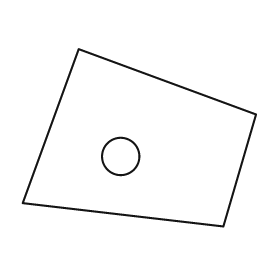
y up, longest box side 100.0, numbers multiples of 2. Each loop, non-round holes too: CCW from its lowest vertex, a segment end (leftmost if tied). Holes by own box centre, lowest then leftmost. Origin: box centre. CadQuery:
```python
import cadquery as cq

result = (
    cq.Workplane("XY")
    .moveTo(36.0, -38.0)
    .lineTo(50.0, 10.0)
    .lineTo(-26.0, 38.0)
    .lineTo(-50.0, -28.0)
    .close()
    .moveTo(-8.0, -8.0)
    .circle(8.0)
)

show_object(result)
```